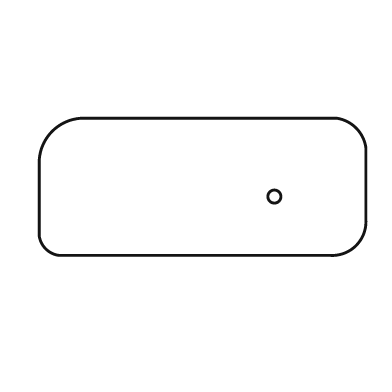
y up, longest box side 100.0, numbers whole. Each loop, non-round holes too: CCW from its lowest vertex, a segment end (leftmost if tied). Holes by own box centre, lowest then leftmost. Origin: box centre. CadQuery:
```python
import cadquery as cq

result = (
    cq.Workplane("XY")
    .moveTo(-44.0, -21.0)
    .lineTo(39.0, -21.0)
    .threePointArc((47.0, -18.0), (50.0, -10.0))
    .lineTo(50.0, 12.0)
    .threePointArc((47.0, 18.0), (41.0, 21.0))
    .lineTo(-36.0, 21.0)
    .threePointArc((-46.0, 17.0), (-50.0, 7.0))
    .lineTo(-50.0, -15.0)
    .threePointArc((-48.0, -19.0), (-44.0, -21.0))
    .close()
    .moveTo(22.0, -3.0)
    .circle(2.0)
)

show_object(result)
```